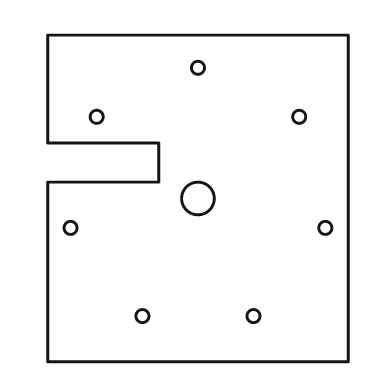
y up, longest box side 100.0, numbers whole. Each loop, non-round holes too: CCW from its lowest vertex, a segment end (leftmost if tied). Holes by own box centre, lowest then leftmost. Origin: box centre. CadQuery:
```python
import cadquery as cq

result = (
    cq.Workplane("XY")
    .moveTo(-46.0, -50.0)
    .lineTo(46.0, -50.0)
    .lineTo(46.0, 50.0)
    .lineTo(-46.0, 50.0)
    .lineTo(-46.0, 17.0)
    .lineTo(-12.0, 17.0)
    .lineTo(-12.0, 5.0)
    .lineTo(-46.0, 5.0)
    .close()
    .moveTo(-17.0, -36.0)
    .circle(2.0)
    .moveTo(17.0, -36.0)
    .circle(2.0)
    .moveTo(-39.0, -9.0)
    .circle(2.0)
    .moveTo(39.0, -9.0)
    .circle(2.0)
    .moveTo(0.0, 0.0)
    .circle(5.0)
    .moveTo(-31.0, 25.0)
    .circle(2.0)
    .moveTo(31.0, 25.0)
    .circle(2.0)
    .moveTo(0.0, 40.0)
    .circle(2.0)
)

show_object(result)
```